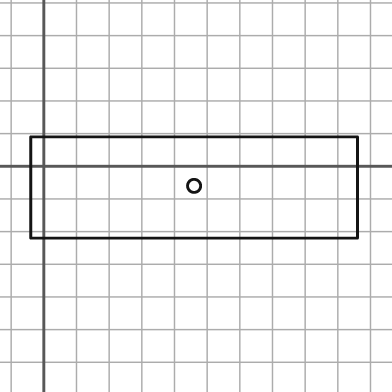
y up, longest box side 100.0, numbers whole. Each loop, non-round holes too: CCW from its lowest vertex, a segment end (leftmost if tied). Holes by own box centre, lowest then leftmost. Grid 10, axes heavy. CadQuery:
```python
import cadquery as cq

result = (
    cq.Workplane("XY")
    .moveTo(-4.0, -22.0)
    .lineTo(96.0, -22.0)
    .lineTo(96.0, 9.0)
    .lineTo(-4.0, 9.0)
    .close()
    .moveTo(46.0, -6.0)
    .circle(2.0)
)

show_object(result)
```